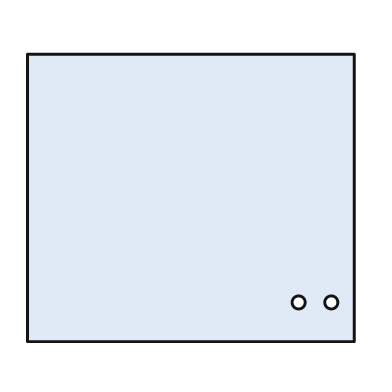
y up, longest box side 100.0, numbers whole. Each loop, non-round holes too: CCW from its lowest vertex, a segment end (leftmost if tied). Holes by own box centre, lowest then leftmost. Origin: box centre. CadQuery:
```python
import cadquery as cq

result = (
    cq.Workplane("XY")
    .moveTo(-50.0, -44.0)
    .lineTo(50.0, -44.0)
    .lineTo(50.0, 44.0)
    .lineTo(-50.0, 44.0)
    .close()
    .moveTo(33.0, -32.0)
    .circle(2.0)
    .moveTo(43.0, -32.0)
    .circle(2.0)
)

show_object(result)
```